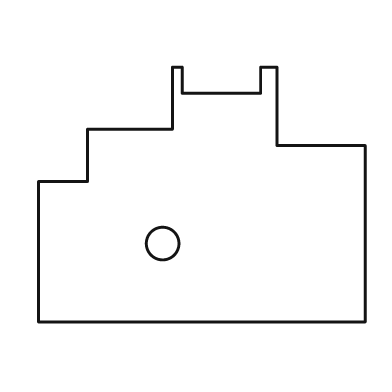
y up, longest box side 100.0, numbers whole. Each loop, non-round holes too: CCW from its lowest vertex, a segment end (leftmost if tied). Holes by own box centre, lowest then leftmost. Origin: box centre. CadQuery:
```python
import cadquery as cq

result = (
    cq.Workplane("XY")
    .moveTo(-50.0, -39.0)
    .lineTo(50.0, -39.0)
    .lineTo(50.0, 15.0)
    .lineTo(23.0, 15.0)
    .lineTo(23.0, 39.0)
    .lineTo(18.0, 39.0)
    .lineTo(18.0, 31.0)
    .lineTo(-6.0, 31.0)
    .lineTo(-6.0, 39.0)
    .lineTo(-9.0, 39.0)
    .lineTo(-9.0, 20.0)
    .lineTo(-35.0, 20.0)
    .lineTo(-35.0, 4.0)
    .lineTo(-50.0, 4.0)
    .close()
    .moveTo(-12.0, -15.0)
    .circle(5.0)
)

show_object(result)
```